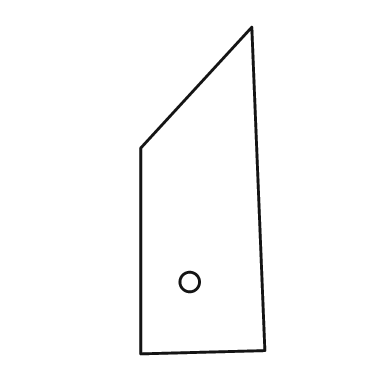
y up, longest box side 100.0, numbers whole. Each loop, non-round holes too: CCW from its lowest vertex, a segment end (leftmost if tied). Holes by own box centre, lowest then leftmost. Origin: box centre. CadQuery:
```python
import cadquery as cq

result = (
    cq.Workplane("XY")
    .moveTo(-19.0, -50.0)
    .lineTo(19.0, -49.0)
    .lineTo(15.0, 50.0)
    .lineTo(-19.0, 13.0)
    .close()
    .moveTo(-4.0, -28.0)
    .circle(3.0)
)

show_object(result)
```